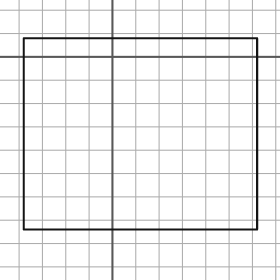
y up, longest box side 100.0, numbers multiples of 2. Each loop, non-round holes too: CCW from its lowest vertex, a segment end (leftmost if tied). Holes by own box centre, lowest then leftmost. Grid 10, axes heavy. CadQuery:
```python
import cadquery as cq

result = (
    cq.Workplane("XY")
    .moveTo(-38.0, -74.0)
    .lineTo(62.0, -74.0)
    .lineTo(62.0, 8.0)
    .lineTo(-38.0, 8.0)
    .close()
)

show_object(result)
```